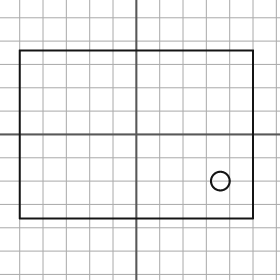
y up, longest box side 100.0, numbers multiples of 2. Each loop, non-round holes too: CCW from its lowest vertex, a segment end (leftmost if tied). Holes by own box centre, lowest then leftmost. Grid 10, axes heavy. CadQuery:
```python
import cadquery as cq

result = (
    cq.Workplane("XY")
    .moveTo(-50.0, -36.0)
    .lineTo(50.0, -36.0)
    .lineTo(50.0, 36.0)
    .lineTo(-50.0, 36.0)
    .close()
    .moveTo(36.0, -20.0)
    .circle(4.0)
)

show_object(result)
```